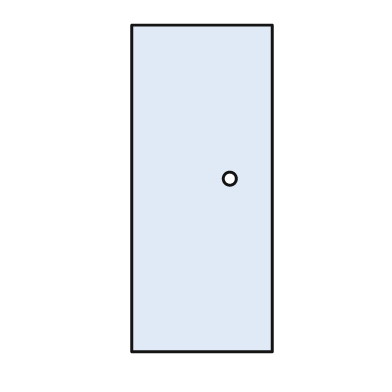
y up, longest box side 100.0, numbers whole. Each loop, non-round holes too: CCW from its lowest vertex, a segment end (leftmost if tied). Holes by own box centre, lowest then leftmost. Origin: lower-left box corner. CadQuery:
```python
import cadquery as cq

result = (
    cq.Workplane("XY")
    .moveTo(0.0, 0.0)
    .lineTo(43.0, 0.0)
    .lineTo(43.0, 100.0)
    .lineTo(0.0, 100.0)
    .close()
    .moveTo(30.0, 53.0)
    .circle(2.0)
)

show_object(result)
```